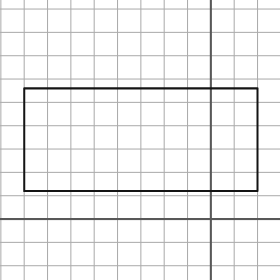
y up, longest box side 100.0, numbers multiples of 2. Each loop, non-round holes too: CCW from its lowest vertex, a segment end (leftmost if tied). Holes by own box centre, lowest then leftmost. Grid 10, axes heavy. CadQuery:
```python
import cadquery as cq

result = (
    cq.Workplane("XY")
    .moveTo(-80.0, 12.0)
    .lineTo(20.0, 12.0)
    .lineTo(20.0, 56.0)
    .lineTo(-80.0, 56.0)
    .close()
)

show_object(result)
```